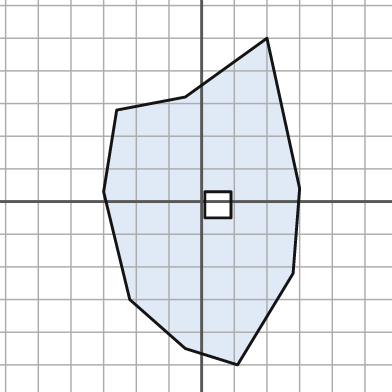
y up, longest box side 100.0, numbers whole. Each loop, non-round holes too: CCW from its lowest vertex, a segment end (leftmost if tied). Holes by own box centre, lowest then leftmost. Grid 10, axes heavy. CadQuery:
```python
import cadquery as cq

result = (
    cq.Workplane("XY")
    .moveTo(11.0, -50.0)
    .lineTo(28.0, -22.0)
    .lineTo(30.0, 4.0)
    .lineTo(20.0, 50.0)
    .lineTo(-5.0, 32.0)
    .lineTo(-26.0, 28.0)
    .lineTo(-30.0, 3.0)
    .lineTo(-22.0, -30.0)
    .lineTo(-5.0, -45.0)
    .close()
    .moveTo(1.0, -5.0)
    .lineTo(9.0, -5.0)
    .lineTo(9.0, 3.0)
    .lineTo(1.0, 3.0)
    .close()
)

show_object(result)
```